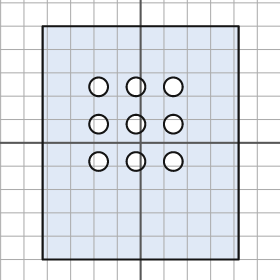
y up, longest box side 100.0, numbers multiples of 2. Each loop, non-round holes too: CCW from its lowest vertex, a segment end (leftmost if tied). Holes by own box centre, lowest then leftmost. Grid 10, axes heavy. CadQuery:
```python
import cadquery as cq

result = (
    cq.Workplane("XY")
    .moveTo(-42.0, -50.0)
    .lineTo(42.0, -50.0)
    .lineTo(42.0, 50.0)
    .lineTo(-42.0, 50.0)
    .close()
    .moveTo(-18.0, -8.0)
    .circle(4.0)
    .moveTo(-2.0, -8.0)
    .circle(4.0)
    .moveTo(14.0, -8.0)
    .circle(4.0)
    .moveTo(-18.0, 8.0)
    .circle(4.0)
    .moveTo(-2.0, 8.0)
    .circle(4.0)
    .moveTo(14.0, 8.0)
    .circle(4.0)
    .moveTo(-18.0, 24.0)
    .circle(4.0)
    .moveTo(-2.0, 24.0)
    .circle(4.0)
    .moveTo(14.0, 24.0)
    .circle(4.0)
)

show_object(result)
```